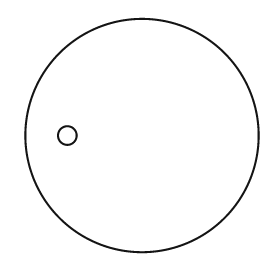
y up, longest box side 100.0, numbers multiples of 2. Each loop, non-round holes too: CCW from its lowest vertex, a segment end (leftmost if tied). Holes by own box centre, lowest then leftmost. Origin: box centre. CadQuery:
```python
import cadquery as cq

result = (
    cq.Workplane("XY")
    .moveTo(0.0, 0.0)
    .circle(50.0)
    .moveTo(-32.0, 0.0)
    .circle(4.0)
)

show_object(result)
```